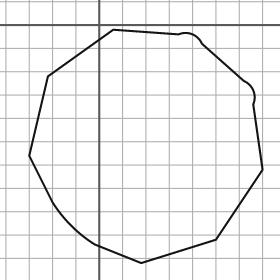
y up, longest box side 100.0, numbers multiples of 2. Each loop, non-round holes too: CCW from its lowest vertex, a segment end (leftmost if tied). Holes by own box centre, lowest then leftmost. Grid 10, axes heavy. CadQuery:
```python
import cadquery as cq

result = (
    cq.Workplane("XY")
    .moveTo(18.0, -102.0)
    .lineTo(50.0, -92.0)
    .lineTo(70.0, -62.0)
    .lineTo(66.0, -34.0)
    .threePointArc((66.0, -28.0), (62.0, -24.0))
    .lineTo(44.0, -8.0)
    .threePointArc((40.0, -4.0), (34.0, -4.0))
    .lineTo(6.0, -2.0)
    .lineTo(-22.0, -22.0)
    .lineTo(-30.0, -56.0)
    .lineTo(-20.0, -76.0)
    .threePointArc((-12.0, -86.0), (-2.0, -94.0))
    .close()
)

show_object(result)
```